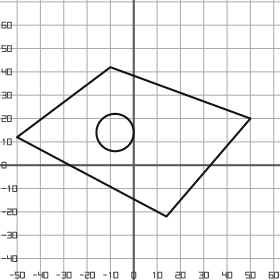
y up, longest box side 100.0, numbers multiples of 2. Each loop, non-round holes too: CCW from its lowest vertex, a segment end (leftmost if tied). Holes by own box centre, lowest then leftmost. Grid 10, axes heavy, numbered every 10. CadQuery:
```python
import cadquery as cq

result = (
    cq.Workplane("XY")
    .moveTo(14.0, -22.0)
    .lineTo(50.0, 20.0)
    .lineTo(-10.0, 42.0)
    .lineTo(-50.0, 12.0)
    .close()
    .moveTo(-8.0, 14.0)
    .circle(8.0)
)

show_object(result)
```